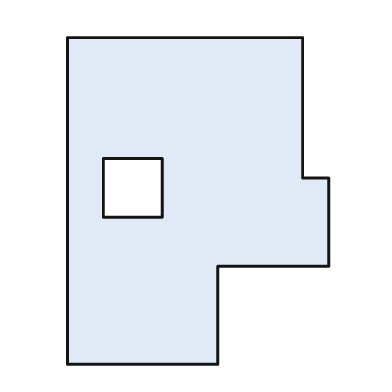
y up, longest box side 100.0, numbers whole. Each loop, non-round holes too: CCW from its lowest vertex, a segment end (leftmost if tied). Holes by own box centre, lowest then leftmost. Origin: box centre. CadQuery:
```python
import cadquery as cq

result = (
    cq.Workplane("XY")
    .moveTo(-40.0, -50.0)
    .lineTo(6.0, -50.0)
    .lineTo(6.0, -20.0)
    .lineTo(40.0, -20.0)
    .lineTo(40.0, 7.0)
    .lineTo(32.0, 7.0)
    .lineTo(32.0, 50.0)
    .lineTo(-40.0, 50.0)
    .close()
    .moveTo(-29.0, -5.0)
    .lineTo(-11.0, -5.0)
    .lineTo(-11.0, 13.0)
    .lineTo(-29.0, 13.0)
    .close()
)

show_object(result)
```